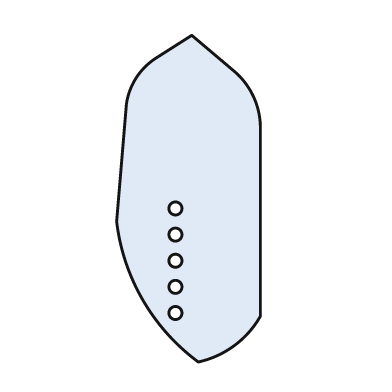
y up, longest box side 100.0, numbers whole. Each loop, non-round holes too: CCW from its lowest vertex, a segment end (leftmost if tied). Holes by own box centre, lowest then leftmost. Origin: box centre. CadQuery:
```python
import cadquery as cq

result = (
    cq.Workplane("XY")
    .moveTo(3.0, -50.0)
    .threePointArc((14.0, -45.0), (22.0, -36.0))
    .lineTo(22.0, 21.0)
    .threePointArc((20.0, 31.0), (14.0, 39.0))
    .lineTo(1.0, 50.0)
    .lineTo(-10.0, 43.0)
    .threePointArc((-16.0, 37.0), (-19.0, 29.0))
    .lineTo(-22.0, -7.0)
    .threePointArc((-14.0, -31.0), (3.0, -50.0))
    .close()
    .moveTo(-4.0, -35.0)
    .circle(2.0)
    .moveTo(-4.0, -27.0)
    .circle(2.0)
    .moveTo(-4.0, -19.0)
    .circle(2.0)
    .moveTo(-4.0, -11.0)
    .circle(2.0)
    .moveTo(-4.0, -3.0)
    .circle(2.0)
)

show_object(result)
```